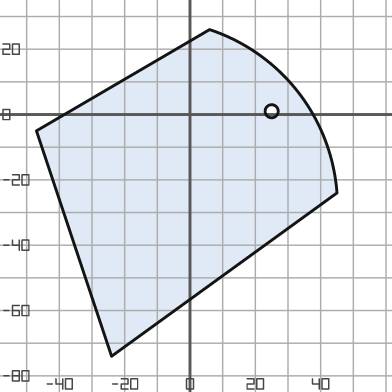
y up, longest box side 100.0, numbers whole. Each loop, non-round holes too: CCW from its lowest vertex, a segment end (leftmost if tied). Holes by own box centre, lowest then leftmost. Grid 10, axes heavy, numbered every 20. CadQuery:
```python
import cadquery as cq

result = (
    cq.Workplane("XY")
    .moveTo(-24.0, -74.0)
    .lineTo(45.0, -24.0)
    .threePointArc((33.0, 7.0), (6.0, 26.0))
    .lineTo(-47.0, -5.0)
    .close()
    .moveTo(25.0, 1.0)
    .circle(2.0)
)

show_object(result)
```